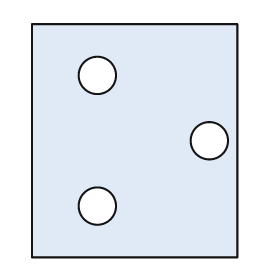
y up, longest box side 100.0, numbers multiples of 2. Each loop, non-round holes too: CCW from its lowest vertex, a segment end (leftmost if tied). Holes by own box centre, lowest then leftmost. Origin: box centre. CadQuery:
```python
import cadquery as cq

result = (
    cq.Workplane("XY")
    .moveTo(-44.0, -50.0)
    .lineTo(44.0, -50.0)
    .lineTo(44.0, 50.0)
    .lineTo(-44.0, 50.0)
    .close()
    .moveTo(-16.0, -28.0)
    .circle(8.0)
    .moveTo(32.0, 0.0)
    .circle(8.0)
    .moveTo(-16.0, 28.0)
    .circle(8.0)
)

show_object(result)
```